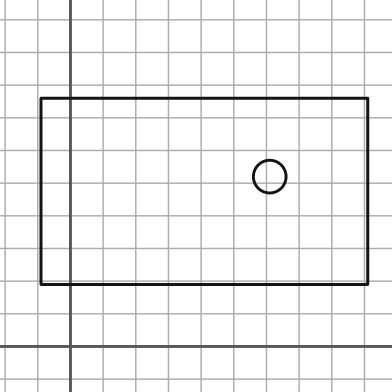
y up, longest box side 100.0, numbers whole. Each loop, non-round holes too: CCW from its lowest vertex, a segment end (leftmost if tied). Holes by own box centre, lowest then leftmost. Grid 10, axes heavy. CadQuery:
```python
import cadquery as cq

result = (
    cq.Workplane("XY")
    .moveTo(-9.0, 19.0)
    .lineTo(91.0, 19.0)
    .lineTo(91.0, 76.0)
    .lineTo(-9.0, 76.0)
    .close()
    .moveTo(61.0, 52.0)
    .circle(5.0)
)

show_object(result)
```